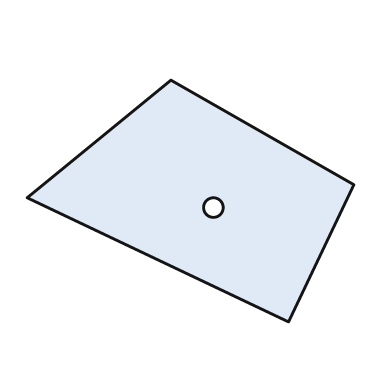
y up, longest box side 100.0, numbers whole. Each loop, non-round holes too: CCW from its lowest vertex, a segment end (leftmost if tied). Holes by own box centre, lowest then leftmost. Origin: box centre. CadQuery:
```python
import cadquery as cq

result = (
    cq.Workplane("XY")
    .moveTo(30.0, -37.0)
    .lineTo(50.0, 5.0)
    .lineTo(-6.0, 37.0)
    .lineTo(-50.0, 1.0)
    .close()
    .moveTo(7.0, -2.0)
    .circle(3.0)
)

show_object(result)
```